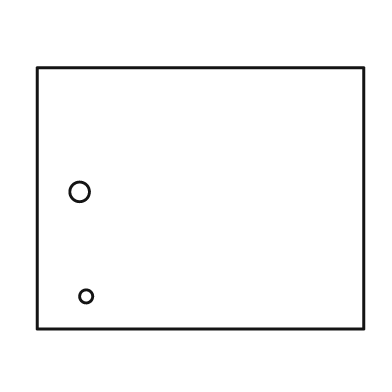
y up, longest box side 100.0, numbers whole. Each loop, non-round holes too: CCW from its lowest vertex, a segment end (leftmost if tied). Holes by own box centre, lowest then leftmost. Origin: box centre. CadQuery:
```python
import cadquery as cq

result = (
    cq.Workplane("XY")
    .moveTo(-50.0, -40.0)
    .lineTo(50.0, -40.0)
    .lineTo(50.0, 40.0)
    .lineTo(-50.0, 40.0)
    .close()
    .moveTo(-35.0, -30.0)
    .circle(2.0)
    .moveTo(-37.0, 2.0)
    .circle(3.0)
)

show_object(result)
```